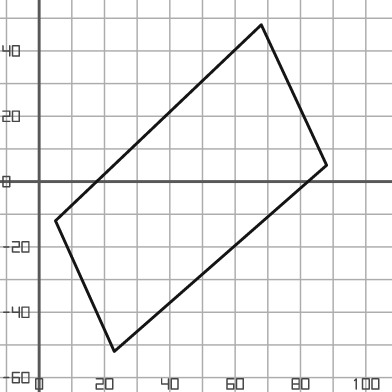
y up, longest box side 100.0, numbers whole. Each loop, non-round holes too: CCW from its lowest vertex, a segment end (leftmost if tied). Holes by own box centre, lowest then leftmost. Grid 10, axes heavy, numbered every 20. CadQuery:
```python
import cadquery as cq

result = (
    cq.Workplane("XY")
    .moveTo(23.0, -52.0)
    .lineTo(88.0, 5.0)
    .lineTo(68.0, 48.0)
    .lineTo(5.0, -12.0)
    .close()
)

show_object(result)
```